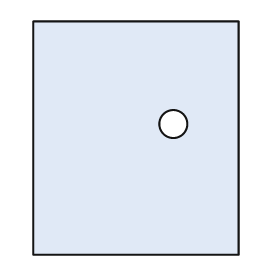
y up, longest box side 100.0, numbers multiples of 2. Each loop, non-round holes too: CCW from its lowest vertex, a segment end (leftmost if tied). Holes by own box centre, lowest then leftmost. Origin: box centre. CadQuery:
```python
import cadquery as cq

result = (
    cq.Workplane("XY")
    .moveTo(-44.0, -50.0)
    .lineTo(44.0, -50.0)
    .lineTo(44.0, 50.0)
    .lineTo(-44.0, 50.0)
    .close()
    .moveTo(16.0, 6.0)
    .circle(6.0)
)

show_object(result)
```